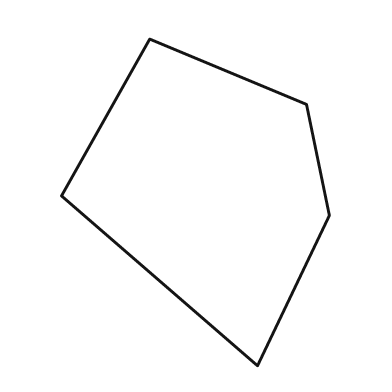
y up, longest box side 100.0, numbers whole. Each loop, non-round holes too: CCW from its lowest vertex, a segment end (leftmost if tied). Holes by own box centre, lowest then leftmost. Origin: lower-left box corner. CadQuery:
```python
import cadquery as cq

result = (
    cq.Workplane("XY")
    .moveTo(60.0, 0.0)
    .lineTo(82.0, 46.0)
    .lineTo(75.0, 80.0)
    .lineTo(27.0, 100.0)
    .lineTo(0.0, 52.0)
    .close()
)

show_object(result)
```